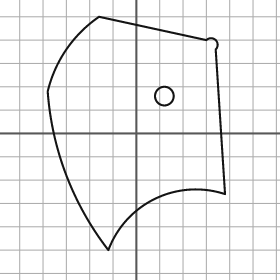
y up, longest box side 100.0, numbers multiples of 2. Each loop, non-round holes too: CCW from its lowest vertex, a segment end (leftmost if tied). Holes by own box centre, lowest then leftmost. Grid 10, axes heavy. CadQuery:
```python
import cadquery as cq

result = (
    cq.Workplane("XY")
    .moveTo(-12.0, -50.0)
    .threePointArc((8.0, -28.0), (38.0, -26.0))
    .lineTo(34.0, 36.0)
    .threePointArc((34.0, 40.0), (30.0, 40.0))
    .lineTo(-16.0, 50.0)
    .threePointArc((-30.0, 36.0), (-38.0, 18.0))
    .threePointArc((-30.0, -18.0), (-12.0, -50.0))
    .close()
    .moveTo(12.0, 16.0)
    .circle(4.0)
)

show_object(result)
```